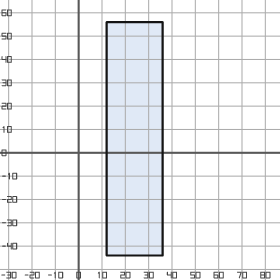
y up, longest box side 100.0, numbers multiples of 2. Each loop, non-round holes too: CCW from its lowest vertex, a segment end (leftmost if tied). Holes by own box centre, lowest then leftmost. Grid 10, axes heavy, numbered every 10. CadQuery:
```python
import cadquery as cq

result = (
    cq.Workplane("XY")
    .moveTo(12.0, -44.0)
    .lineTo(36.0, -44.0)
    .lineTo(36.0, 56.0)
    .lineTo(12.0, 56.0)
    .close()
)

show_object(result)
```